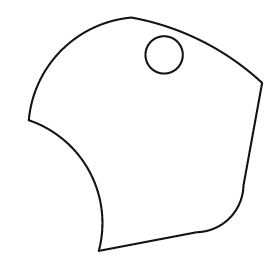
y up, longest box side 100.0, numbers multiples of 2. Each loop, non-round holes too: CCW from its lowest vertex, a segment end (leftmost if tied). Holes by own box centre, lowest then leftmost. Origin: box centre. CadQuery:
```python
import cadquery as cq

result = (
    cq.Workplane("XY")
    .moveTo(-20.0, -50.0)
    .lineTo(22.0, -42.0)
    .threePointArc((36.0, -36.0), (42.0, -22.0))
    .lineTo(50.0, 22.0)
    .threePointArc((24.0, 40.0), (-6.0, 50.0))
    .threePointArc((-36.0, 36.0), (-50.0, 6.0))
    .threePointArc((-24.0, -16.0), (-20.0, -50.0))
    .close()
    .moveTo(8.0, 34.0)
    .circle(8.0)
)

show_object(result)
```